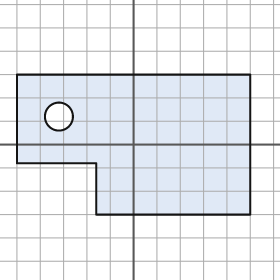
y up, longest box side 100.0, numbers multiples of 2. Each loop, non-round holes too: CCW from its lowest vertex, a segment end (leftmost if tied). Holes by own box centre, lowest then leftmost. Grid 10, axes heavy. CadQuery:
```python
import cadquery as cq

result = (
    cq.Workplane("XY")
    .moveTo(-16.0, -30.0)
    .lineTo(50.0, -30.0)
    .lineTo(50.0, 30.0)
    .lineTo(-50.0, 30.0)
    .lineTo(-50.0, -8.0)
    .lineTo(-16.0, -8.0)
    .close()
    .moveTo(-32.0, 12.0)
    .circle(6.0)
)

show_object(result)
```